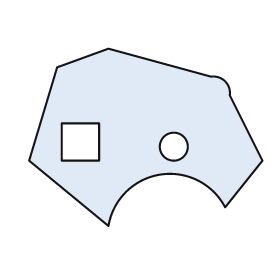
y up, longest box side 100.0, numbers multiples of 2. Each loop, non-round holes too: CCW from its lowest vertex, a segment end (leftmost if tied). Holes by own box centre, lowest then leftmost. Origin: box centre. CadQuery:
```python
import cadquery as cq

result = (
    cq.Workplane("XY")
    .moveTo(-16.0, -38.0)
    .threePointArc((6.0, -16.0), (34.0, -30.0))
    .lineTo(50.0, -10.0)
    .lineTo(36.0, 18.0)
    .threePointArc((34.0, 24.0), (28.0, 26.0))
    .lineTo(-16.0, 38.0)
    .lineTo(-38.0, 30.0)
    .lineTo(-50.0, -10.0)
    .close()
    .moveTo(12.0, -4.0)
    .circle(6.0)
    .moveTo(-36.0, -10.0)
    .lineTo(-20.0, -10.0)
    .lineTo(-20.0, 6.0)
    .lineTo(-36.0, 6.0)
    .close()
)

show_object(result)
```